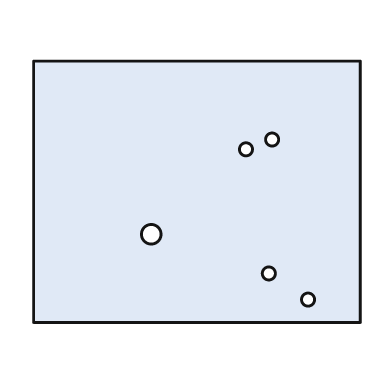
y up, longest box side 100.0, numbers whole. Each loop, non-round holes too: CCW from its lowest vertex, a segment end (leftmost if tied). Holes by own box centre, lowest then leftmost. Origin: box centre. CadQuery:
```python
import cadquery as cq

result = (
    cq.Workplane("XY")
    .moveTo(-50.0, -40.0)
    .lineTo(50.0, -40.0)
    .lineTo(50.0, 40.0)
    .lineTo(-50.0, 40.0)
    .close()
    .moveTo(34.0, -33.0)
    .circle(2.0)
    .moveTo(22.0, -25.0)
    .circle(2.0)
    .moveTo(-14.0, -13.0)
    .circle(3.0)
    .moveTo(15.0, 13.0)
    .circle(2.0)
    .moveTo(23.0, 16.0)
    .circle(2.0)
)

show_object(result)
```